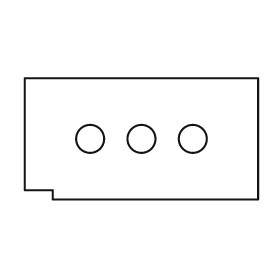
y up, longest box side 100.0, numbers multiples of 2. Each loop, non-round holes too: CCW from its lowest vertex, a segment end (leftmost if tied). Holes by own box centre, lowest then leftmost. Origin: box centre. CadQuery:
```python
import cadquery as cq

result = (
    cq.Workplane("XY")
    .moveTo(-38.0, -26.0)
    .lineTo(50.0, -26.0)
    .lineTo(50.0, 26.0)
    .lineTo(-50.0, 26.0)
    .lineTo(-50.0, -22.0)
    .lineTo(-38.0, -22.0)
    .close()
    .moveTo(-22.0, 0.0)
    .circle(6.0)
    .moveTo(0.0, 0.0)
    .circle(6.0)
    .moveTo(22.0, 0.0)
    .circle(6.0)
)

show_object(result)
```